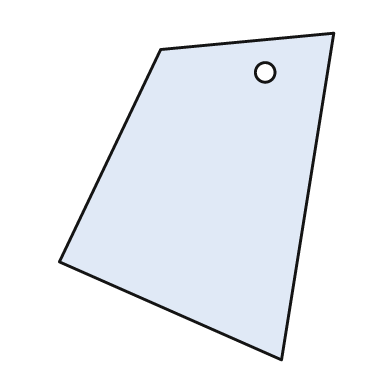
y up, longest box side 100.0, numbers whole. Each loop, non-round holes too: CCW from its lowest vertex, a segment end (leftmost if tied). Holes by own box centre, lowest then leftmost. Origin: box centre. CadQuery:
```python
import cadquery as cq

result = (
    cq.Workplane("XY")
    .moveTo(26.0, -50.0)
    .lineTo(42.0, 50.0)
    .lineTo(-11.0, 45.0)
    .lineTo(-42.0, -20.0)
    .close()
    .moveTo(21.0, 38.0)
    .circle(3.0)
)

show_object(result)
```